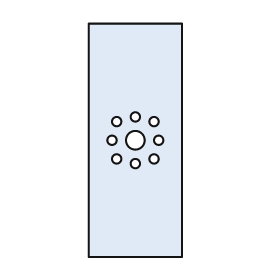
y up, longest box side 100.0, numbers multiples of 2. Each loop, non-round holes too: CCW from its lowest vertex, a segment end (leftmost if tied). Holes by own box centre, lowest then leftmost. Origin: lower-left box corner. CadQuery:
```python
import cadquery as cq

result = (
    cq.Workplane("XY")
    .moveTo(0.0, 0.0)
    .lineTo(40.0, 0.0)
    .lineTo(40.0, 100.0)
    .lineTo(0.0, 100.0)
    .close()
    .moveTo(20.0, 40.0)
    .circle(2.0)
    .moveTo(12.0, 42.0)
    .circle(2.0)
    .moveTo(28.0, 42.0)
    .circle(2.0)
    .moveTo(10.0, 50.0)
    .circle(2.0)
    .moveTo(20.0, 50.0)
    .circle(4.0)
    .moveTo(30.0, 50.0)
    .circle(2.0)
    .moveTo(12.0, 58.0)
    .circle(2.0)
    .moveTo(28.0, 58.0)
    .circle(2.0)
    .moveTo(20.0, 60.0)
    .circle(2.0)
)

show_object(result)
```